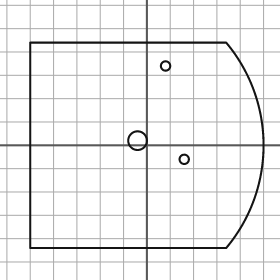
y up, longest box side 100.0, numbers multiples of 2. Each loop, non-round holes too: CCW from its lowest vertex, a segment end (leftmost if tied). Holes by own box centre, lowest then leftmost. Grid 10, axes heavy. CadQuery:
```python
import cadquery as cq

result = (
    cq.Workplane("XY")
    .moveTo(-50.0, -44.0)
    .lineTo(34.0, -44.0)
    .threePointArc((50.0, 0.0), (34.0, 44.0))
    .lineTo(-50.0, 44.0)
    .close()
    .moveTo(16.0, -6.0)
    .circle(2.0)
    .moveTo(-4.0, 2.0)
    .circle(4.0)
    .moveTo(8.0, 34.0)
    .circle(2.0)
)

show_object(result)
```